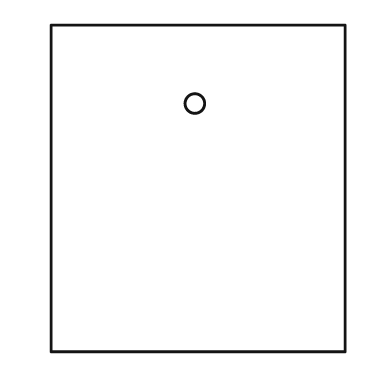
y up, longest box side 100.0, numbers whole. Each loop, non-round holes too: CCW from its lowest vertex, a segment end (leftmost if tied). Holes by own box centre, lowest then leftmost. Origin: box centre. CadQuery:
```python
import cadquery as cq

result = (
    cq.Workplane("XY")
    .moveTo(-45.0, -50.0)
    .lineTo(45.0, -50.0)
    .lineTo(45.0, 50.0)
    .lineTo(-45.0, 50.0)
    .close()
    .moveTo(-1.0, 26.0)
    .circle(3.0)
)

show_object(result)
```